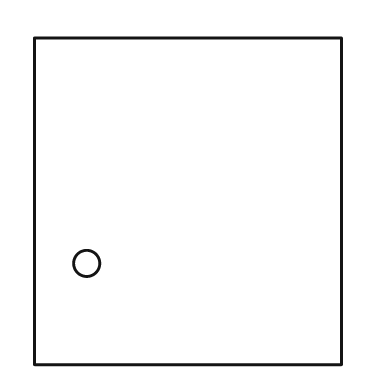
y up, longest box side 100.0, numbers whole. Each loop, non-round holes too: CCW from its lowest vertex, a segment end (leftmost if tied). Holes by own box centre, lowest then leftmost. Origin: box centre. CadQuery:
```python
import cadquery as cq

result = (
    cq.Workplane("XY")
    .moveTo(-47.0, -50.0)
    .lineTo(47.0, -50.0)
    .lineTo(47.0, 50.0)
    .lineTo(-47.0, 50.0)
    .close()
    .moveTo(-31.0, -19.0)
    .circle(4.0)
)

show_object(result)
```